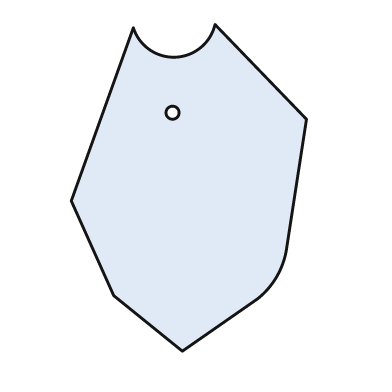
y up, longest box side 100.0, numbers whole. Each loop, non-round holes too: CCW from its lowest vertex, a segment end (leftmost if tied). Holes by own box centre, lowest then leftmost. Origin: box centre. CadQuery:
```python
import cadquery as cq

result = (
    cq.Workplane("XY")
    .moveTo(-2.0, -50.0)
    .lineTo(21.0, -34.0)
    .threePointArc((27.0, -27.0), (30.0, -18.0))
    .lineTo(36.0, 21.0)
    .lineTo(8.0, 50.0)
    .threePointArc((-4.0, 40.0), (-17.0, 49.0))
    .lineTo(-36.0, -4.0)
    .lineTo(-23.0, -33.0)
    .close()
    .moveTo(-5.0, 23.0)
    .circle(2.0)
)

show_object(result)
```